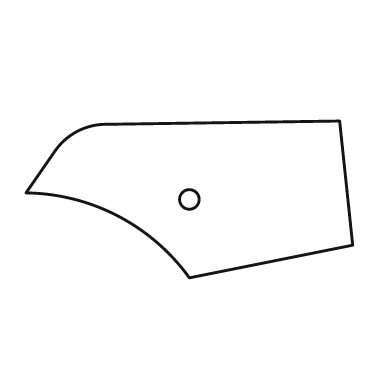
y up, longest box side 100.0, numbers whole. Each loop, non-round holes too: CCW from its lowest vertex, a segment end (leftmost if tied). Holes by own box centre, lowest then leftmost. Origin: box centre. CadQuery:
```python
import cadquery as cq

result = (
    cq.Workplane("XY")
    .moveTo(0.0, -24.0)
    .lineTo(50.0, -14.0)
    .lineTo(46.0, 24.0)
    .lineTo(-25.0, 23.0)
    .threePointArc((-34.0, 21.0), (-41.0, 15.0))
    .lineTo(-50.0, 2.0)
    .threePointArc((-22.0, -5.0), (0.0, -24.0))
    .close()
    .moveTo(0.0, 0.0)
    .circle(3.0)
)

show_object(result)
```